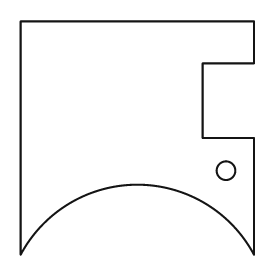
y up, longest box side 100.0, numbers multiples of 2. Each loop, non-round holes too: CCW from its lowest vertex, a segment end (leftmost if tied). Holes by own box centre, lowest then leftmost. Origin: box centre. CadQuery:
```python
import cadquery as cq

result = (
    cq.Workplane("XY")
    .moveTo(-50.0, -50.0)
    .threePointArc((0.0, -20.0), (50.0, -50.0))
    .lineTo(50.0, 0.0)
    .lineTo(28.0, 0.0)
    .lineTo(28.0, 32.0)
    .lineTo(50.0, 32.0)
    .lineTo(50.0, 50.0)
    .lineTo(-50.0, 50.0)
    .close()
    .moveTo(38.0, -14.0)
    .circle(4.0)
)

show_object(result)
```